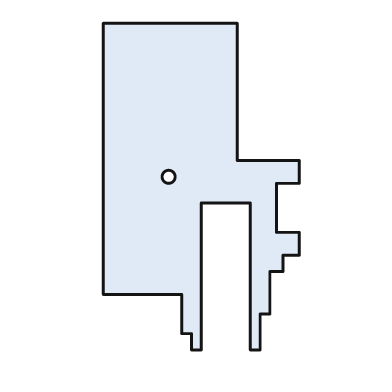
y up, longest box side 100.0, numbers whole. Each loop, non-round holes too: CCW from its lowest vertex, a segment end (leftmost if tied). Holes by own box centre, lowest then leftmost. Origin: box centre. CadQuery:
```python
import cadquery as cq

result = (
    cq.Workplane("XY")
    .moveTo(-3.0, -50.0)
    .lineTo(0.0, -50.0)
    .lineTo(0.0, -5.0)
    .lineTo(15.0, -5.0)
    .lineTo(15.0, -50.0)
    .lineTo(18.0, -50.0)
    .lineTo(18.0, -39.0)
    .lineTo(21.0, -39.0)
    .lineTo(21.0, -26.0)
    .lineTo(25.0, -26.0)
    .lineTo(25.0, -21.0)
    .lineTo(30.0, -21.0)
    .lineTo(30.0, -14.0)
    .lineTo(23.0, -14.0)
    .lineTo(23.0, 1.0)
    .lineTo(30.0, 1.0)
    .lineTo(30.0, 8.0)
    .lineTo(11.0, 8.0)
    .lineTo(11.0, 50.0)
    .lineTo(-30.0, 50.0)
    .lineTo(-30.0, -33.0)
    .lineTo(-6.0, -33.0)
    .lineTo(-6.0, -45.0)
    .lineTo(-3.0, -45.0)
    .close()
    .moveTo(-10.0, 3.0)
    .circle(2.0)
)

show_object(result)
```